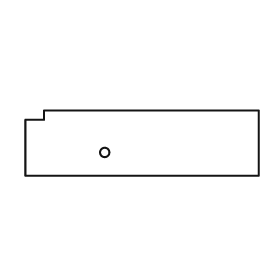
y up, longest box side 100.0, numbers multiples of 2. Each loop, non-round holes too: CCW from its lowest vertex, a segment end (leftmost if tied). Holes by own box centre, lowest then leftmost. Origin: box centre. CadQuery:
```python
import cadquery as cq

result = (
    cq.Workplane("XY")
    .moveTo(-50.0, -14.0)
    .lineTo(50.0, -14.0)
    .lineTo(50.0, 14.0)
    .lineTo(-42.0, 14.0)
    .lineTo(-42.0, 10.0)
    .lineTo(-50.0, 10.0)
    .close()
    .moveTo(-16.0, -4.0)
    .circle(2.0)
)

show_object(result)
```